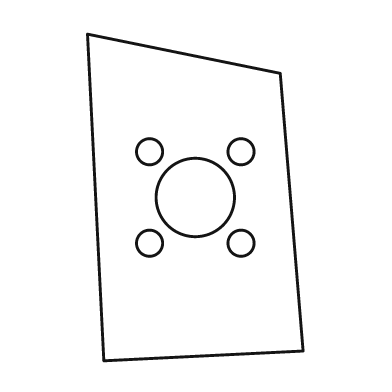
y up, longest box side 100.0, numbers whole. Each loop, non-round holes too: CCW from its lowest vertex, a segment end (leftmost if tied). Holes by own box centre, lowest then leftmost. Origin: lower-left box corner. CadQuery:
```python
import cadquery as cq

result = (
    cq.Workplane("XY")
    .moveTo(5.0, 0.0)
    .lineTo(66.0, 3.0)
    .lineTo(59.0, 88.0)
    .lineTo(0.0, 100.0)
    .close()
    .moveTo(19.0, 36.0)
    .circle(4.0)
    .moveTo(47.0, 36.0)
    .circle(4.0)
    .moveTo(33.0, 50.0)
    .circle(12.0)
    .moveTo(19.0, 64.0)
    .circle(4.0)
    .moveTo(47.0, 64.0)
    .circle(4.0)
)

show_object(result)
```